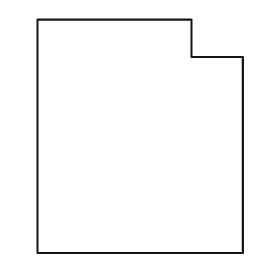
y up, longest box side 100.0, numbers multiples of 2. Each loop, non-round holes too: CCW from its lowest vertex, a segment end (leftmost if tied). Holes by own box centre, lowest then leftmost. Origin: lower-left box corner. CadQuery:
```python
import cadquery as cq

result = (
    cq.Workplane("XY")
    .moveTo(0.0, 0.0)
    .lineTo(88.0, 0.0)
    .lineTo(88.0, 84.0)
    .lineTo(66.0, 84.0)
    .lineTo(66.0, 100.0)
    .lineTo(0.0, 100.0)
    .close()
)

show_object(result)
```